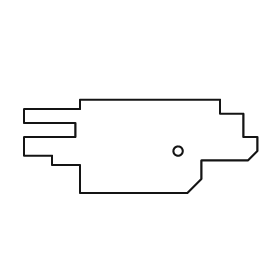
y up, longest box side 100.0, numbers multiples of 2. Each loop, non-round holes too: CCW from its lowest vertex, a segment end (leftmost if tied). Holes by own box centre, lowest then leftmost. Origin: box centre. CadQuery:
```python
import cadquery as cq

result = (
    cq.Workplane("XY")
    .moveTo(-26.0, -20.0)
    .lineTo(20.0, -20.0)
    .lineTo(26.0, -14.0)
    .lineTo(26.0, -6.0)
    .lineTo(46.0, -6.0)
    .lineTo(50.0, -2.0)
    .lineTo(50.0, 4.0)
    .lineTo(44.0, 4.0)
    .lineTo(44.0, 14.0)
    .lineTo(34.0, 14.0)
    .lineTo(34.0, 20.0)
    .lineTo(-26.0, 20.0)
    .lineTo(-26.0, 16.0)
    .lineTo(-50.0, 16.0)
    .lineTo(-50.0, 10.0)
    .lineTo(-28.0, 10.0)
    .lineTo(-28.0, 4.0)
    .lineTo(-50.0, 4.0)
    .lineTo(-50.0, -4.0)
    .lineTo(-38.0, -4.0)
    .lineTo(-38.0, -8.0)
    .lineTo(-26.0, -8.0)
    .close()
    .moveTo(16.0, -2.0)
    .circle(2.0)
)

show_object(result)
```